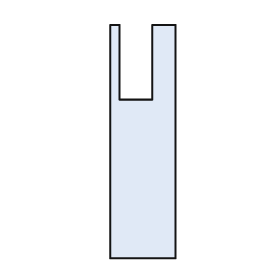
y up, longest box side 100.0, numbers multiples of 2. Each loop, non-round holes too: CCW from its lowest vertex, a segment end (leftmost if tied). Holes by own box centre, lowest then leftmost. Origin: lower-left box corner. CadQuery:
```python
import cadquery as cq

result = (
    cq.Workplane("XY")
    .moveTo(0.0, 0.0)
    .lineTo(28.0, 0.0)
    .lineTo(28.0, 100.0)
    .lineTo(18.0, 100.0)
    .lineTo(18.0, 68.0)
    .lineTo(4.0, 68.0)
    .lineTo(4.0, 100.0)
    .lineTo(0.0, 100.0)
    .close()
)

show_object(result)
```